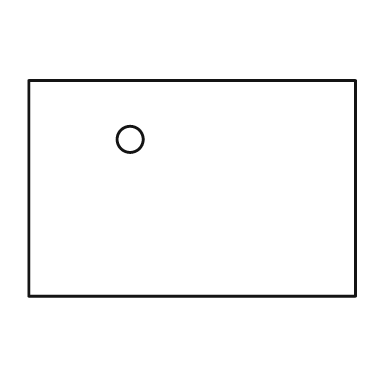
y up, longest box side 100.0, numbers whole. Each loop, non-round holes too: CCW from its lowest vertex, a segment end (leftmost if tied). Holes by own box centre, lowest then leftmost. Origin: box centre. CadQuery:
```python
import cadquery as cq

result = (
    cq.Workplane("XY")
    .moveTo(-50.0, -33.0)
    .lineTo(50.0, -33.0)
    .lineTo(50.0, 33.0)
    .lineTo(-50.0, 33.0)
    .close()
    .moveTo(-19.0, 15.0)
    .circle(4.0)
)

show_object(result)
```